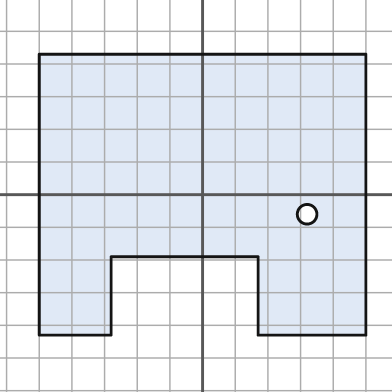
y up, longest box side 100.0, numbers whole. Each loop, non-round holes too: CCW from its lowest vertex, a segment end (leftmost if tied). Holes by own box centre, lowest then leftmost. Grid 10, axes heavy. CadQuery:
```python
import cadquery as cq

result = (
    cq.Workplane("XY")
    .moveTo(-50.0, -43.0)
    .lineTo(-28.0, -43.0)
    .lineTo(-28.0, -19.0)
    .lineTo(17.0, -19.0)
    .lineTo(17.0, -43.0)
    .lineTo(50.0, -43.0)
    .lineTo(50.0, 43.0)
    .lineTo(-50.0, 43.0)
    .close()
    .moveTo(32.0, -6.0)
    .circle(3.0)
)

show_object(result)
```